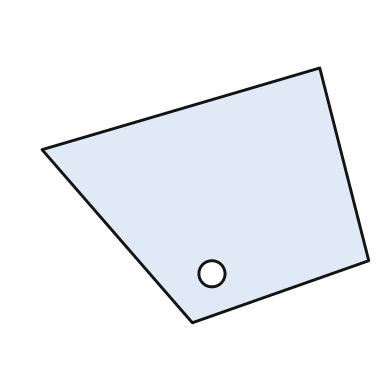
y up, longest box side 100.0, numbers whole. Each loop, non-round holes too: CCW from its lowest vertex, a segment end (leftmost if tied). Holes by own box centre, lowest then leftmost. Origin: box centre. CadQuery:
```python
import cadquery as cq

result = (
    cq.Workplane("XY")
    .moveTo(-4.0, -39.0)
    .lineTo(50.0, -20.0)
    .lineTo(35.0, 39.0)
    .lineTo(-50.0, 14.0)
    .close()
    .moveTo(2.0, -24.0)
    .circle(4.0)
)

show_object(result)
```